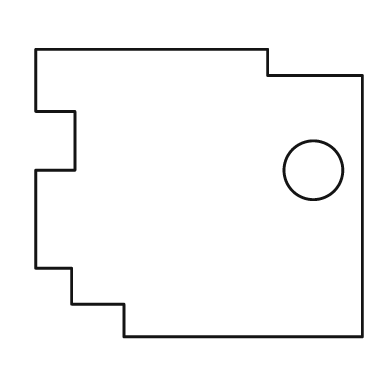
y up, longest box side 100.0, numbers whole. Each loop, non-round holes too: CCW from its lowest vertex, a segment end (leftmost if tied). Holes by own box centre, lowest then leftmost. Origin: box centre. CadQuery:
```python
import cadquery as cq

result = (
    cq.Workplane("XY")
    .moveTo(-23.0, -44.0)
    .lineTo(50.0, -44.0)
    .lineTo(50.0, 36.0)
    .lineTo(21.0, 36.0)
    .lineTo(21.0, 44.0)
    .lineTo(-50.0, 44.0)
    .lineTo(-50.0, 25.0)
    .lineTo(-38.0, 25.0)
    .lineTo(-38.0, 7.0)
    .lineTo(-50.0, 7.0)
    .lineTo(-50.0, -23.0)
    .lineTo(-39.0, -23.0)
    .lineTo(-39.0, -34.0)
    .lineTo(-23.0, -34.0)
    .close()
    .moveTo(35.0, 7.0)
    .circle(9.0)
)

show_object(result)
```